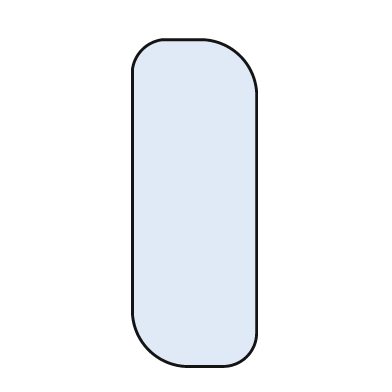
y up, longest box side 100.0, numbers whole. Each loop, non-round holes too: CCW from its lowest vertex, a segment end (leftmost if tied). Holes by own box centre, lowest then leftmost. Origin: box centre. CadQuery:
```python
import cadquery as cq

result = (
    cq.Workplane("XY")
    .moveTo(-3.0, -50.0)
    .lineTo(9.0, -50.0)
    .threePointArc((16.0, -47.0), (19.0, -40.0))
    .lineTo(19.0, 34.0)
    .threePointArc((14.0, 45.0), (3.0, 50.0))
    .lineTo(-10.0, 50.0)
    .threePointArc((-16.0, 47.0), (-19.0, 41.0))
    .lineTo(-19.0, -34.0)
    .threePointArc((-14.0, -45.0), (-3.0, -50.0))
    .close()
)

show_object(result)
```